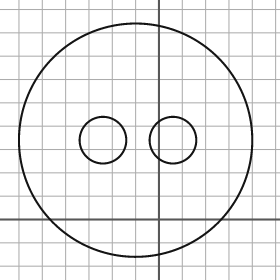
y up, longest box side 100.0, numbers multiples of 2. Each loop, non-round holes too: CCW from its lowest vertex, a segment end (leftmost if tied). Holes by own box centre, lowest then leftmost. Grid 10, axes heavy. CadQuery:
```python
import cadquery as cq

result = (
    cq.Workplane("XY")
    .moveTo(-10.0, 34.0)
    .circle(50.0)
    .moveTo(-24.0, 34.0)
    .circle(10.0)
    .moveTo(6.0, 34.0)
    .circle(10.0)
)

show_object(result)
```